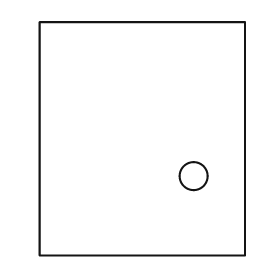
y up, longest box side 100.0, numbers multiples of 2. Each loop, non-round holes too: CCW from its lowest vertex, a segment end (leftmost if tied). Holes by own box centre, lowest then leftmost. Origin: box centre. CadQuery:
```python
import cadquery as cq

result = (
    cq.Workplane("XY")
    .moveTo(-44.0, -50.0)
    .lineTo(44.0, -50.0)
    .lineTo(44.0, 50.0)
    .lineTo(-44.0, 50.0)
    .close()
    .moveTo(22.0, -16.0)
    .circle(6.0)
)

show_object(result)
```